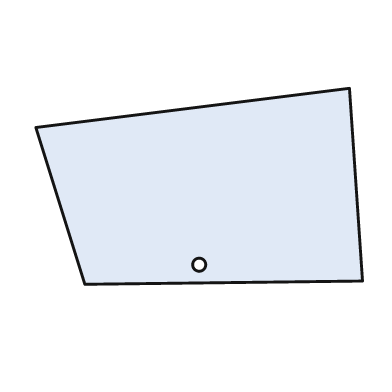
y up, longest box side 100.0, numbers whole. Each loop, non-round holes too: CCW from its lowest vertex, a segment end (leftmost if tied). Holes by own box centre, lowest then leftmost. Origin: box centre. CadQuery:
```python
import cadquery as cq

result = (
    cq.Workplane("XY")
    .moveTo(-35.0, -30.0)
    .lineTo(50.0, -29.0)
    .lineTo(46.0, 30.0)
    .lineTo(-50.0, 18.0)
    .close()
    .moveTo(0.0, -24.0)
    .circle(2.0)
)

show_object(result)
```